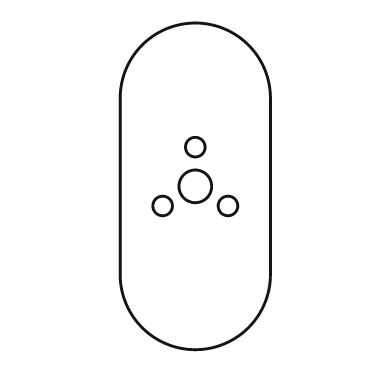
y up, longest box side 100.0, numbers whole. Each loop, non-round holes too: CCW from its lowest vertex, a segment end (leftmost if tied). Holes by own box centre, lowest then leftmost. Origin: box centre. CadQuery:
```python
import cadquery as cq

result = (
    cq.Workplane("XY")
    .moveTo(-23.0, -27.0)
    .threePointArc((0.0, -50.0), (23.0, -27.0))
    .lineTo(23.0, 27.0)
    .threePointArc((0.0, 50.0), (-23.0, 27.0))
    .close()
    .moveTo(-10.0, -6.0)
    .circle(3.0)
    .moveTo(10.0, -6.0)
    .circle(3.0)
    .moveTo(0.0, 0.0)
    .circle(5.0)
    .moveTo(0.0, 12.0)
    .circle(3.0)
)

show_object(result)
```